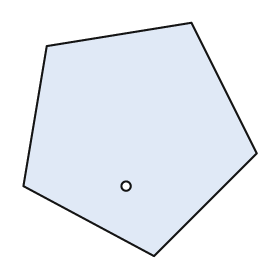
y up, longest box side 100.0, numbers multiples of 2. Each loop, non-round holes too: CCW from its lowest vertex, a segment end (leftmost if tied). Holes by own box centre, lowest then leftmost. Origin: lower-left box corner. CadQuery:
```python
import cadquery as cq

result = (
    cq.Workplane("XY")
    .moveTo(56.0, 0.0)
    .lineTo(100.0, 44.0)
    .lineTo(72.0, 100.0)
    .lineTo(10.0, 90.0)
    .lineTo(0.0, 30.0)
    .close()
    .moveTo(44.0, 30.0)
    .circle(2.0)
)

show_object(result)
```